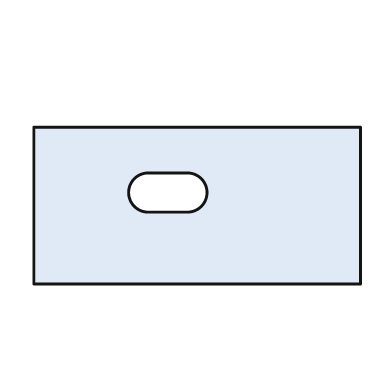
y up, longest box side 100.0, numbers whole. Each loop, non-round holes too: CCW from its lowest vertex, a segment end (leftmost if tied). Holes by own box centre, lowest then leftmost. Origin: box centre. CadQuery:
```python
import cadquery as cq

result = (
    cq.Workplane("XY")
    .moveTo(-50.0, -24.0)
    .lineTo(50.0, -24.0)
    .lineTo(50.0, 24.0)
    .lineTo(-50.0, 24.0)
    .close()
    .moveTo(-15.0, -2.0)
    .lineTo(-3.0, -2.0)
    .threePointArc((3.0, 4.0), (-3.0, 10.0))
    .lineTo(-15.0, 10.0)
    .threePointArc((-21.0, 4.0), (-15.0, -2.0))
    .close()
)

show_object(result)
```